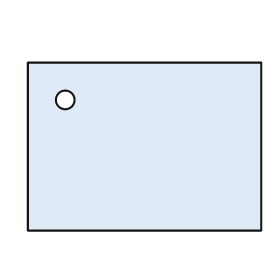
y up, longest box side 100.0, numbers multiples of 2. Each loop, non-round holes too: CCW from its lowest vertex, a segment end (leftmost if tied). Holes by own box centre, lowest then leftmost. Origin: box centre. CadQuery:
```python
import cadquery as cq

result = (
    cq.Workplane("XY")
    .moveTo(-50.0, -36.0)
    .lineTo(50.0, -36.0)
    .lineTo(50.0, 36.0)
    .lineTo(-50.0, 36.0)
    .close()
    .moveTo(-34.0, 20.0)
    .circle(4.0)
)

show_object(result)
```